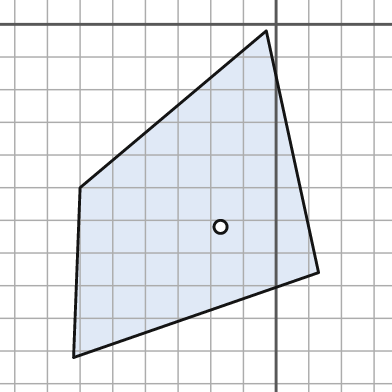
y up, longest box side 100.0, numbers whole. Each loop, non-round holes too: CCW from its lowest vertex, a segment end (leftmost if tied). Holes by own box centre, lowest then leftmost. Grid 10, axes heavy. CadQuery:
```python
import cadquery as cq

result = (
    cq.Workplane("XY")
    .moveTo(-62.0, -102.0)
    .lineTo(13.0, -76.0)
    .lineTo(-3.0, -2.0)
    .lineTo(-60.0, -50.0)
    .close()
    .moveTo(-17.0, -62.0)
    .circle(2.0)
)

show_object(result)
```